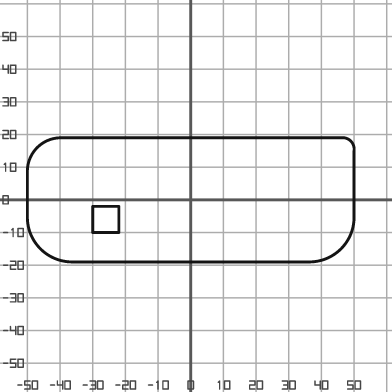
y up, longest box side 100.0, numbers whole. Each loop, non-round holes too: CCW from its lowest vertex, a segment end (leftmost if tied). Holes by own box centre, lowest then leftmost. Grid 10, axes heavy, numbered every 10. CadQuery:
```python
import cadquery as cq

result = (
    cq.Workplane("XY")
    .moveTo(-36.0, -19.0)
    .lineTo(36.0, -19.0)
    .threePointArc((46.0, -15.0), (50.0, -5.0))
    .lineTo(50.0, 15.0)
    .threePointArc((49.0, 18.0), (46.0, 19.0))
    .lineTo(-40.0, 19.0)
    .threePointArc((-47.0, 16.0), (-50.0, 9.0))
    .lineTo(-50.0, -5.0)
    .threePointArc((-46.0, -15.0), (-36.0, -19.0))
    .close()
    .moveTo(-30.0, -10.0)
    .lineTo(-22.0, -10.0)
    .lineTo(-22.0, -2.0)
    .lineTo(-30.0, -2.0)
    .close()
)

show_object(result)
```